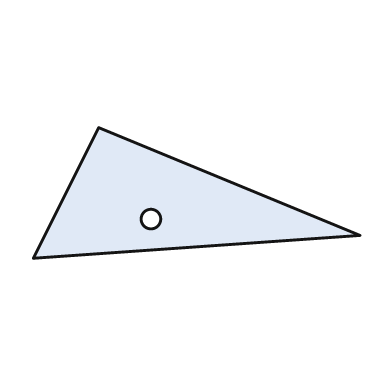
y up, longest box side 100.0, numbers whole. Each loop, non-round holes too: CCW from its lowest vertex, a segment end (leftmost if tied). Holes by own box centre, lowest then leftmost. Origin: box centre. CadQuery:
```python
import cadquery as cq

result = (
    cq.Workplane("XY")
    .moveTo(-50.0, -20.0)
    .lineTo(50.0, -13.0)
    .lineTo(-30.0, 20.0)
    .close()
    .moveTo(-14.0, -8.0)
    .circle(3.0)
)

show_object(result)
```